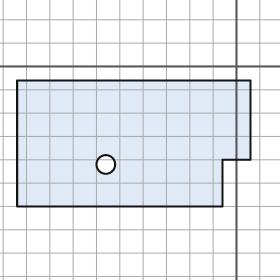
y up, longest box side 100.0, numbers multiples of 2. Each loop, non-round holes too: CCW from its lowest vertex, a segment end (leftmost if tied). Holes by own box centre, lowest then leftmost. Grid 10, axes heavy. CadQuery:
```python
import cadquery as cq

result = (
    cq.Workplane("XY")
    .moveTo(-94.0, -60.0)
    .lineTo(-6.0, -60.0)
    .lineTo(-6.0, -40.0)
    .lineTo(6.0, -40.0)
    .lineTo(6.0, -6.0)
    .lineTo(-94.0, -6.0)
    .close()
    .moveTo(-56.0, -42.0)
    .circle(4.0)
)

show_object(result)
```